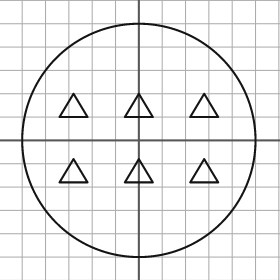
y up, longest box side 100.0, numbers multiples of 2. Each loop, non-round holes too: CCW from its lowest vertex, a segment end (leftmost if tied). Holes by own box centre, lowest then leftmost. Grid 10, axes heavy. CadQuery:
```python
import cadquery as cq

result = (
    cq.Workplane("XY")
    .moveTo(0.0, 0.0)
    .circle(50.0)
    .moveTo(-34.0, -18.0)
    .lineTo(-22.0, -18.0)
    .lineTo(-28.0, -8.0)
    .close()
    .moveTo(-6.0, -18.0)
    .lineTo(6.0, -18.0)
    .lineTo(0.0, -8.0)
    .close()
    .moveTo(22.0, -18.0)
    .lineTo(34.0, -18.0)
    .lineTo(28.0, -8.0)
    .close()
    .moveTo(-34.0, 10.0)
    .lineTo(-22.0, 10.0)
    .lineTo(-28.0, 20.0)
    .close()
    .moveTo(-6.0, 10.0)
    .lineTo(6.0, 10.0)
    .lineTo(0.0, 20.0)
    .close()
    .moveTo(22.0, 10.0)
    .lineTo(34.0, 10.0)
    .lineTo(28.0, 20.0)
    .close()
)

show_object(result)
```